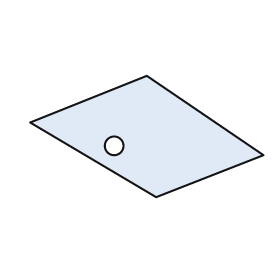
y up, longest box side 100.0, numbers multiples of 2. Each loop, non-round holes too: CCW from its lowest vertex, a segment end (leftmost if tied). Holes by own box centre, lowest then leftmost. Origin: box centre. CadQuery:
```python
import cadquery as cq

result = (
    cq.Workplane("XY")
    .moveTo(4.0, -26.0)
    .lineTo(50.0, -8.0)
    .lineTo(0.0, 26.0)
    .lineTo(-50.0, 6.0)
    .close()
    .moveTo(-14.0, -4.0)
    .circle(4.0)
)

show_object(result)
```